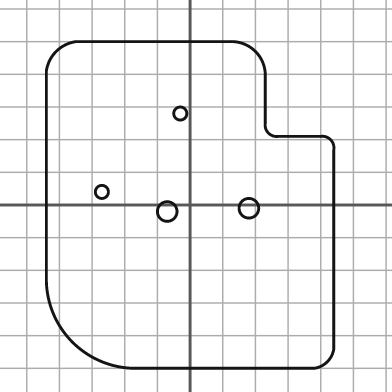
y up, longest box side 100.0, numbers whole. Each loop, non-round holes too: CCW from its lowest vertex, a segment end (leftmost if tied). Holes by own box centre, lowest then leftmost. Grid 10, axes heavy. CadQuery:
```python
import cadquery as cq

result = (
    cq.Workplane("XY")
    .moveTo(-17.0, -50.0)
    .lineTo(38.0, -50.0)
    .threePointArc((42.0, -48.0), (44.0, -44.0))
    .lineTo(44.0, 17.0)
    .threePointArc((43.0, 20.0), (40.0, 21.0))
    .lineTo(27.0, 21.0)
    .threePointArc((24.0, 22.0), (23.0, 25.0))
    .lineTo(23.0, 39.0)
    .threePointArc((20.0, 47.0), (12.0, 50.0))
    .lineTo(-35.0, 50.0)
    .threePointArc((-41.0, 47.0), (-44.0, 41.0))
    .lineTo(-44.0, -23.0)
    .threePointArc((-36.0, -42.0), (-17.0, -50.0))
    .close()
    .moveTo(-7.0, -2.0)
    .circle(3.0)
    .moveTo(18.0, -1.0)
    .circle(3.0)
    .moveTo(-27.0, 4.0)
    .circle(2.0)
    .moveTo(-3.0, 28.0)
    .circle(2.0)
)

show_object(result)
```